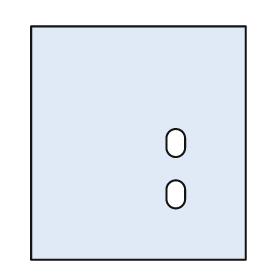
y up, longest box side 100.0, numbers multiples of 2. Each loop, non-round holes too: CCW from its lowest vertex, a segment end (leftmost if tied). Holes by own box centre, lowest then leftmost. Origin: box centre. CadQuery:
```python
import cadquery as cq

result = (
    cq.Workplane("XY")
    .moveTo(-46.0, -50.0)
    .lineTo(46.0, -50.0)
    .lineTo(46.0, 50.0)
    .lineTo(-46.0, 50.0)
    .close()
    .moveTo(12.0, -24.0)
    .threePointArc((16.0, -28.0), (20.0, -24.0))
    .lineTo(20.0, -20.0)
    .threePointArc((16.0, -16.0), (12.0, -20.0))
    .close()
    .moveTo(12.0, -2.0)
    .threePointArc((16.0, -6.0), (20.0, -2.0))
    .lineTo(20.0, 2.0)
    .threePointArc((16.0, 6.0), (12.0, 2.0))
    .close()
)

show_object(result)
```